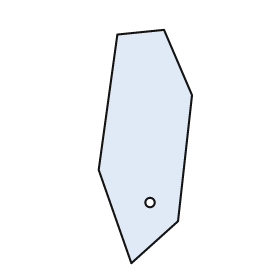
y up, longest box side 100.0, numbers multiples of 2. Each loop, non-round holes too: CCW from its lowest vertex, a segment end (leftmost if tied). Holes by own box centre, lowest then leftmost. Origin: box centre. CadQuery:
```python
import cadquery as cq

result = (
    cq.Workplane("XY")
    .moveTo(-6.0, -50.0)
    .lineTo(14.0, -32.0)
    .lineTo(20.0, 22.0)
    .lineTo(8.0, 50.0)
    .lineTo(-12.0, 48.0)
    .lineTo(-20.0, -10.0)
    .close()
    .moveTo(2.0, -24.0)
    .circle(2.0)
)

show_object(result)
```